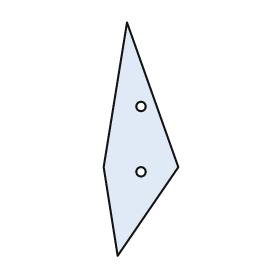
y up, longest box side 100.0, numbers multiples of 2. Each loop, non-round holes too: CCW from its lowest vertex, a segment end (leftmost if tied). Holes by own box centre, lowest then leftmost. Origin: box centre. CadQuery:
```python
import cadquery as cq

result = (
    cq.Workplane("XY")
    .moveTo(-10.0, -50.0)
    .lineTo(16.0, -12.0)
    .lineTo(-6.0, 50.0)
    .lineTo(-16.0, -12.0)
    .close()
    .moveTo(0.0, -14.0)
    .circle(2.0)
    .moveTo(0.0, 14.0)
    .circle(2.0)
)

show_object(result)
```